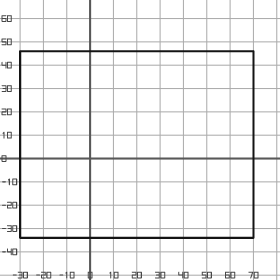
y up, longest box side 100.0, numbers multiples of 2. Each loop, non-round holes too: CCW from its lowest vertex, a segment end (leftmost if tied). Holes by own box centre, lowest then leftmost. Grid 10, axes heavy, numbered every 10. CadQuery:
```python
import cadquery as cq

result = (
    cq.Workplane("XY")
    .moveTo(-30.0, -34.0)
    .lineTo(70.0, -34.0)
    .lineTo(70.0, 46.0)
    .lineTo(-30.0, 46.0)
    .close()
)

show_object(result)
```